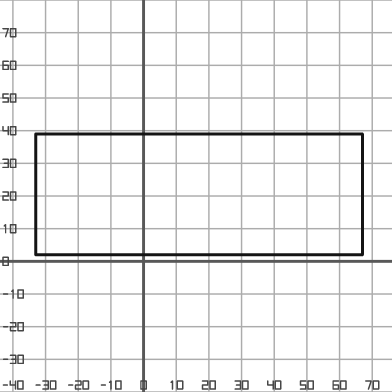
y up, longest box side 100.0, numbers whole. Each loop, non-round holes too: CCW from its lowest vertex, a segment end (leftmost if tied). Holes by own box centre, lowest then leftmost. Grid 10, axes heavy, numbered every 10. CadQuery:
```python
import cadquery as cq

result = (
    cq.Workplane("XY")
    .moveTo(-33.0, 2.0)
    .lineTo(67.0, 2.0)
    .lineTo(67.0, 39.0)
    .lineTo(-33.0, 39.0)
    .close()
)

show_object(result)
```